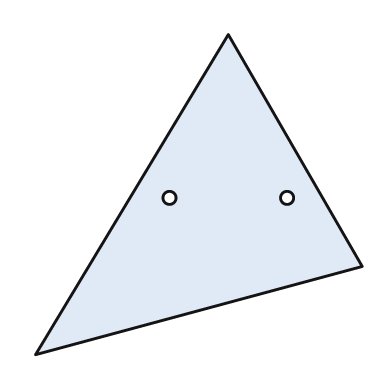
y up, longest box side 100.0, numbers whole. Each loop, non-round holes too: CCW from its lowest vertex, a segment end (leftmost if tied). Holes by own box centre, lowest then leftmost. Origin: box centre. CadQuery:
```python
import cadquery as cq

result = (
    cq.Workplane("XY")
    .moveTo(-50.0, -49.0)
    .lineTo(50.0, -22.0)
    .lineTo(9.0, 49.0)
    .close()
    .moveTo(-9.0, -1.0)
    .circle(2.0)
    .moveTo(27.0, -1.0)
    .circle(2.0)
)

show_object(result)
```